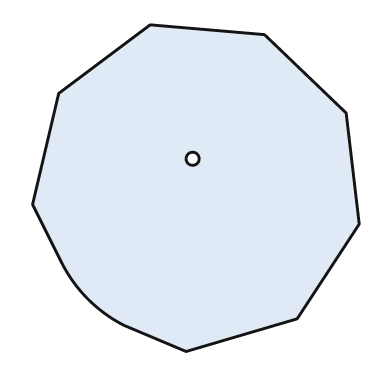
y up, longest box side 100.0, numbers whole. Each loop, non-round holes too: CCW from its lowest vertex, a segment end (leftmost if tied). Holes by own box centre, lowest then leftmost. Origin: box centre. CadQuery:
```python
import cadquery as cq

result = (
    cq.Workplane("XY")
    .moveTo(-3.0, -50.0)
    .lineTo(31.0, -40.0)
    .lineTo(50.0, -11.0)
    .lineTo(46.0, 23.0)
    .lineTo(21.0, 47.0)
    .lineTo(-14.0, 50.0)
    .lineTo(-42.0, 29.0)
    .lineTo(-50.0, -5.0)
    .lineTo(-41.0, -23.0)
    .threePointArc((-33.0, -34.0), (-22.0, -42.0))
    .close()
    .moveTo(-1.0, 9.0)
    .circle(2.0)
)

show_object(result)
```